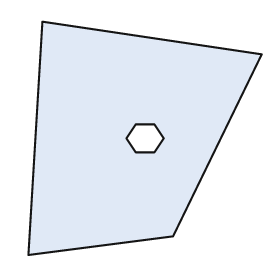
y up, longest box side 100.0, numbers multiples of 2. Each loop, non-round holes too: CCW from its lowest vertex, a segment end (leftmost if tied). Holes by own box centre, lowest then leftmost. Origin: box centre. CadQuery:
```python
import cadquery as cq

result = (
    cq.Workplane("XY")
    .moveTo(-50.0, -50.0)
    .lineTo(12.0, -42.0)
    .lineTo(50.0, 36.0)
    .lineTo(-44.0, 50.0)
    .close()
    .moveTo(-4.0, -6.0)
    .lineTo(4.0, -6.0)
    .lineTo(8.0, 0.0)
    .lineTo(4.0, 6.0)
    .lineTo(-4.0, 6.0)
    .lineTo(-8.0, 0.0)
    .close()
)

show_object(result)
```